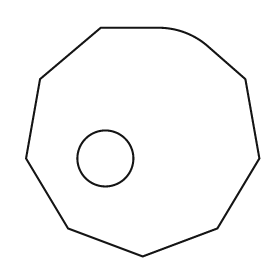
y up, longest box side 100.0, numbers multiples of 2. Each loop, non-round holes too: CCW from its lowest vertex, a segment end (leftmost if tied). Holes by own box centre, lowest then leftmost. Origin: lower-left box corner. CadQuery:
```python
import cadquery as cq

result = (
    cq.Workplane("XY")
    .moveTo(50.0, 0.0)
    .lineTo(82.0, 12.0)
    .lineTo(100.0, 42.0)
    .lineTo(94.0, 76.0)
    .lineTo(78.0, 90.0)
    .threePointArc((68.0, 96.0), (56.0, 98.0))
    .lineTo(32.0, 98.0)
    .lineTo(6.0, 76.0)
    .lineTo(0.0, 42.0)
    .lineTo(18.0, 12.0)
    .close()
    .moveTo(34.0, 42.0)
    .circle(12.0)
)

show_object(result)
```